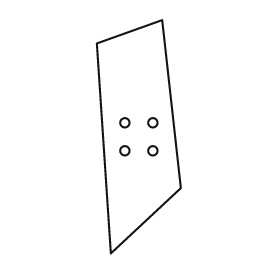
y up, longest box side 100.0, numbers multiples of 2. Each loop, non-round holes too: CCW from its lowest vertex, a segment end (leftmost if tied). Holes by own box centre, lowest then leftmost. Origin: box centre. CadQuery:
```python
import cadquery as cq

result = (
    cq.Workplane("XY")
    .moveTo(-12.0, -50.0)
    .lineTo(18.0, -22.0)
    .lineTo(10.0, 50.0)
    .lineTo(-18.0, 40.0)
    .close()
    .moveTo(-6.0, -6.0)
    .circle(2.0)
    .moveTo(6.0, -6.0)
    .circle(2.0)
    .moveTo(-6.0, 6.0)
    .circle(2.0)
    .moveTo(6.0, 6.0)
    .circle(2.0)
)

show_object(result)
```